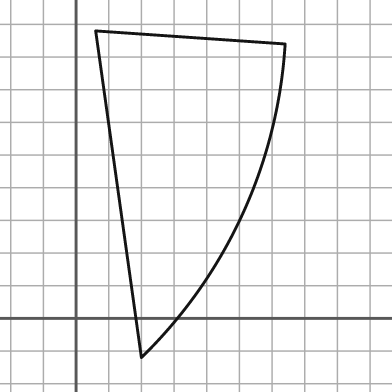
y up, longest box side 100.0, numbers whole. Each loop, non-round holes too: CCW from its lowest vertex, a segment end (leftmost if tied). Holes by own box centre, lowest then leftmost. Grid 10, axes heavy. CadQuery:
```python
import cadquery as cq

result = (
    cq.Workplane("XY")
    .moveTo(20.0, -12.0)
    .threePointArc((51.0, 32.0), (64.0, 84.0))
    .lineTo(6.0, 88.0)
    .close()
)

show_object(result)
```